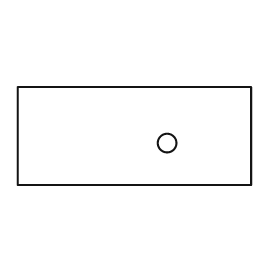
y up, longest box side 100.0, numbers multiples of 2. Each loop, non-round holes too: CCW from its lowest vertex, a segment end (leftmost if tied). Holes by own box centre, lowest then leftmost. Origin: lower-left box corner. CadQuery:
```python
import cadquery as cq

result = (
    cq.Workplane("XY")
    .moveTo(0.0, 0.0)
    .lineTo(100.0, 0.0)
    .lineTo(100.0, 42.0)
    .lineTo(0.0, 42.0)
    .close()
    .moveTo(64.0, 18.0)
    .circle(4.0)
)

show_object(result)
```